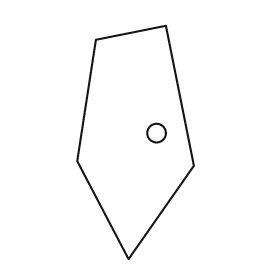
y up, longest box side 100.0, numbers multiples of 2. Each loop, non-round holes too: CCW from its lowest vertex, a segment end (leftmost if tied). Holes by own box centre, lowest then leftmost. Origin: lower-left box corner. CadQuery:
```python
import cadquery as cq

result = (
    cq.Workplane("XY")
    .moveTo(22.0, 0.0)
    .lineTo(50.0, 40.0)
    .lineTo(38.0, 100.0)
    .lineTo(8.0, 94.0)
    .lineTo(0.0, 42.0)
    .close()
    .moveTo(34.0, 54.0)
    .circle(4.0)
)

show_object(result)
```